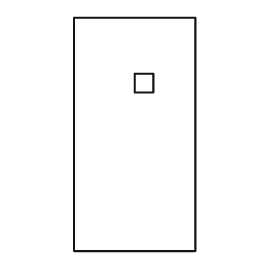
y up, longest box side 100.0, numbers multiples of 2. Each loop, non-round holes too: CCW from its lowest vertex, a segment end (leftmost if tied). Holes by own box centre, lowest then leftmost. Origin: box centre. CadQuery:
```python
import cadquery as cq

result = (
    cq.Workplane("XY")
    .moveTo(-26.0, -50.0)
    .lineTo(26.0, -50.0)
    .lineTo(26.0, 50.0)
    .lineTo(-26.0, 50.0)
    .close()
    .moveTo(0.0, 18.0)
    .lineTo(8.0, 18.0)
    .lineTo(8.0, 26.0)
    .lineTo(0.0, 26.0)
    .close()
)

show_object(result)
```